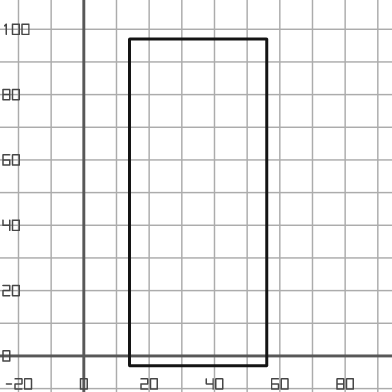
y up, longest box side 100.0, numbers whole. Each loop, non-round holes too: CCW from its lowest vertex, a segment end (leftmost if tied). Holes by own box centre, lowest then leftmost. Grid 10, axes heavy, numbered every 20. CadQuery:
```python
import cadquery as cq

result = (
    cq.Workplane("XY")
    .moveTo(14.0, -3.0)
    .lineTo(56.0, -3.0)
    .lineTo(56.0, 97.0)
    .lineTo(14.0, 97.0)
    .close()
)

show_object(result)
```